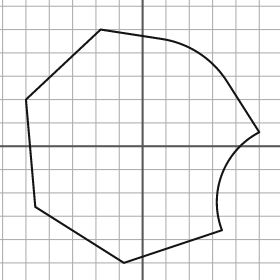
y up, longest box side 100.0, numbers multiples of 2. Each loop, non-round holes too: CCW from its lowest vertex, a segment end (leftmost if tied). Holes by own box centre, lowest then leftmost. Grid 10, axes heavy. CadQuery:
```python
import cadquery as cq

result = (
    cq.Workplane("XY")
    .moveTo(-8.0, -50.0)
    .lineTo(34.0, -36.0)
    .threePointArc((34.0, -12.0), (50.0, 6.0))
    .lineTo(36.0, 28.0)
    .threePointArc((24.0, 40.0), (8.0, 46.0))
    .lineTo(-18.0, 50.0)
    .lineTo(-50.0, 20.0)
    .lineTo(-46.0, -26.0)
    .close()
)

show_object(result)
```